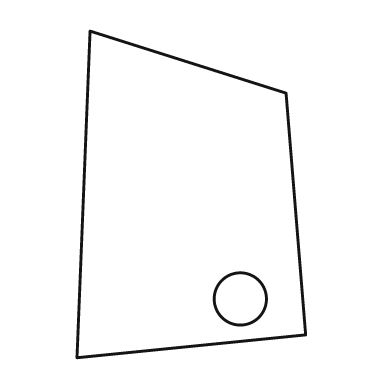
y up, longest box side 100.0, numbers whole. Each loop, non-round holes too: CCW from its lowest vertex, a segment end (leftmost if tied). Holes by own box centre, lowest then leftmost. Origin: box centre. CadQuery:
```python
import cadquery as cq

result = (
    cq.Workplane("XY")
    .moveTo(-35.0, -50.0)
    .lineTo(35.0, -43.0)
    .lineTo(29.0, 31.0)
    .lineTo(-31.0, 50.0)
    .close()
    .moveTo(15.0, -32.0)
    .circle(8.0)
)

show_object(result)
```